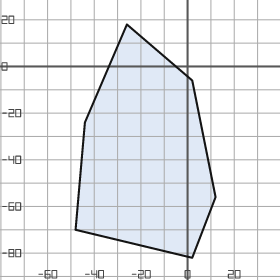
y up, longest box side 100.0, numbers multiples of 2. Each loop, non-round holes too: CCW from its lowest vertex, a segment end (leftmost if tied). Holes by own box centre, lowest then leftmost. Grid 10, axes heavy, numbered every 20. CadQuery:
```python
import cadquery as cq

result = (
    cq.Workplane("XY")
    .moveTo(2.0, -82.0)
    .lineTo(12.0, -56.0)
    .lineTo(2.0, -6.0)
    .lineTo(-26.0, 18.0)
    .lineTo(-44.0, -24.0)
    .lineTo(-48.0, -70.0)
    .close()
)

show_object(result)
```